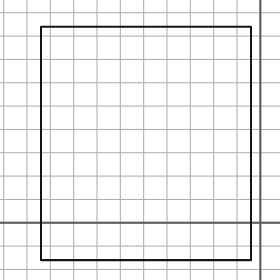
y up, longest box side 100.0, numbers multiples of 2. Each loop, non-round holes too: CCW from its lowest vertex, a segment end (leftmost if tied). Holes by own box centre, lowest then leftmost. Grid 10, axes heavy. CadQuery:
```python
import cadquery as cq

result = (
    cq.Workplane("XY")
    .moveTo(-94.0, -16.0)
    .lineTo(-4.0, -16.0)
    .lineTo(-4.0, 84.0)
    .lineTo(-94.0, 84.0)
    .close()
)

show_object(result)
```